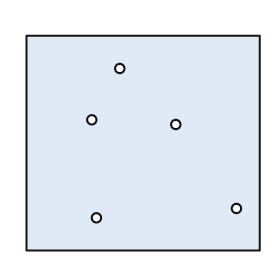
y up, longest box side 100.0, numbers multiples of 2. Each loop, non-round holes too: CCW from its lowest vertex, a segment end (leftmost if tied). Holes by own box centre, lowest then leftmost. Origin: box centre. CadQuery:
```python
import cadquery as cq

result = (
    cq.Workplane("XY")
    .moveTo(-50.0, -46.0)
    .lineTo(50.0, -46.0)
    .lineTo(50.0, 46.0)
    .lineTo(-50.0, 46.0)
    .close()
    .moveTo(-20.0, -32.0)
    .circle(2.0)
    .moveTo(40.0, -28.0)
    .circle(2.0)
    .moveTo(14.0, 8.0)
    .circle(2.0)
    .moveTo(-22.0, 10.0)
    .circle(2.0)
    .moveTo(-10.0, 32.0)
    .circle(2.0)
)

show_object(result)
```